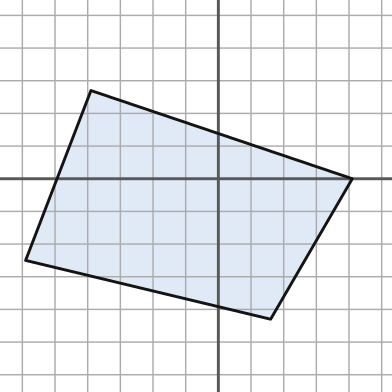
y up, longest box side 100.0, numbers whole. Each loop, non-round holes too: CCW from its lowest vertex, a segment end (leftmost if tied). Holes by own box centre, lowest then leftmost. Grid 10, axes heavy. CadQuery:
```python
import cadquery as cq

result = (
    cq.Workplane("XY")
    .moveTo(16.0, -43.0)
    .lineTo(41.0, 0.0)
    .lineTo(-39.0, 27.0)
    .lineTo(-59.0, -25.0)
    .close()
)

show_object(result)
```